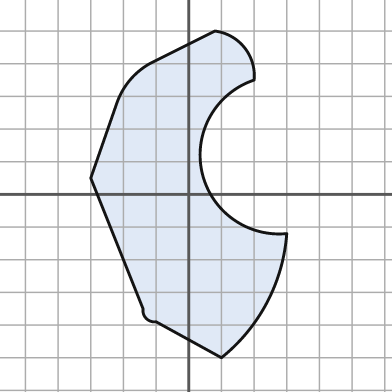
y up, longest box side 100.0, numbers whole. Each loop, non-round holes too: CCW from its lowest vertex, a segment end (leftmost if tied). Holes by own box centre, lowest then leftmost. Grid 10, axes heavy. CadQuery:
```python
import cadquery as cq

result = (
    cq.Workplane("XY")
    .moveTo(10.0, -50.0)
    .threePointArc((24.0, -33.0), (30.0, -12.0))
    .threePointArc((4.0, 7.0), (20.0, 35.0))
    .threePointArc((17.0, 45.0), (8.0, 50.0))
    .lineTo(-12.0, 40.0)
    .threePointArc((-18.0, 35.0), (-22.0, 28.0))
    .lineTo(-30.0, 5.0)
    .lineTo(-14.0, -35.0)
    .threePointArc((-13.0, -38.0), (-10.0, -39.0))
    .close()
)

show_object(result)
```